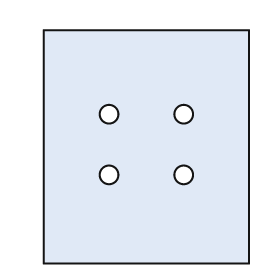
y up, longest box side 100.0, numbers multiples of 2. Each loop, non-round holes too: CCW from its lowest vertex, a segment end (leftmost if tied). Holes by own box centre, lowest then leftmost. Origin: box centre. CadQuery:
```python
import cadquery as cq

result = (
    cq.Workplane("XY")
    .moveTo(-44.0, -50.0)
    .lineTo(44.0, -50.0)
    .lineTo(44.0, 50.0)
    .lineTo(-44.0, 50.0)
    .close()
    .moveTo(-16.0, -12.0)
    .circle(4.0)
    .moveTo(16.0, -12.0)
    .circle(4.0)
    .moveTo(-16.0, 14.0)
    .circle(4.0)
    .moveTo(16.0, 14.0)
    .circle(4.0)
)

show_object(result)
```